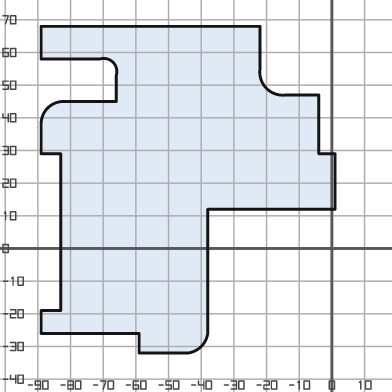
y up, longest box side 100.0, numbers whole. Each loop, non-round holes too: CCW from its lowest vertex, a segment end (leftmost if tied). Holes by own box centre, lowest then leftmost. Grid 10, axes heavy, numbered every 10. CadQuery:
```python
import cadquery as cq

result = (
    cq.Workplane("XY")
    .moveTo(-59.0, -32.0)
    .lineTo(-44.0, -32.0)
    .threePointArc((-40.0, -30.0), (-38.0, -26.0))
    .lineTo(-38.0, 12.0)
    .lineTo(1.0, 12.0)
    .lineTo(1.0, 29.0)
    .lineTo(-4.0, 29.0)
    .lineTo(-4.0, 47.0)
    .lineTo(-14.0, 47.0)
    .threePointArc((-20.0, 49.0), (-22.0, 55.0))
    .lineTo(-22.0, 68.0)
    .lineTo(-89.0, 68.0)
    .lineTo(-89.0, 58.0)
    .lineTo(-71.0, 58.0)
    .threePointArc((-67.0, 57.0), (-66.0, 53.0))
    .lineTo(-66.0, 45.0)
    .lineTo(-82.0, 45.0)
    .threePointArc((-87.0, 43.0), (-89.0, 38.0))
    .lineTo(-89.0, 29.0)
    .lineTo(-83.0, 29.0)
    .lineTo(-83.0, -19.0)
    .lineTo(-89.0, -19.0)
    .lineTo(-89.0, -26.0)
    .lineTo(-59.0, -26.0)
    .close()
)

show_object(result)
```